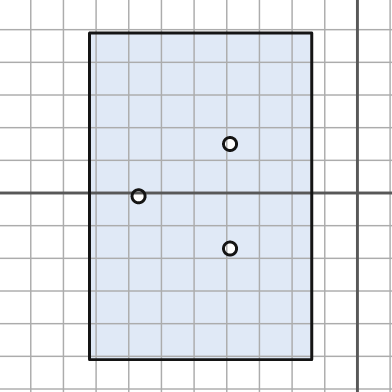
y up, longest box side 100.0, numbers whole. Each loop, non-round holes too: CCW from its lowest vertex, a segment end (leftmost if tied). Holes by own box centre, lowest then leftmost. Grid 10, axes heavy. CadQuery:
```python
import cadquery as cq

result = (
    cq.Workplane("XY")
    .moveTo(-82.0, -51.0)
    .lineTo(-14.0, -51.0)
    .lineTo(-14.0, 49.0)
    .lineTo(-82.0, 49.0)
    .close()
    .moveTo(-39.0, -17.0)
    .circle(2.0)
    .moveTo(-67.0, -1.0)
    .circle(2.0)
    .moveTo(-39.0, 15.0)
    .circle(2.0)
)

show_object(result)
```